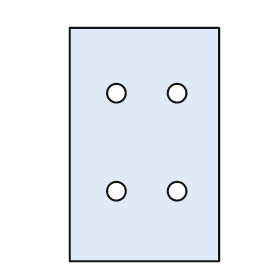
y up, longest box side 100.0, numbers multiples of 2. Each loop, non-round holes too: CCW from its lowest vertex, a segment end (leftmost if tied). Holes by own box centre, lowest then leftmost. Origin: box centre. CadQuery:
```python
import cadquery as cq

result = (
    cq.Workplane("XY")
    .moveTo(-32.0, -50.0)
    .lineTo(32.0, -50.0)
    .lineTo(32.0, 50.0)
    .lineTo(-32.0, 50.0)
    .close()
    .moveTo(-12.0, -20.0)
    .circle(4.0)
    .moveTo(14.0, -20.0)
    .circle(4.0)
    .moveTo(-12.0, 22.0)
    .circle(4.0)
    .moveTo(14.0, 22.0)
    .circle(4.0)
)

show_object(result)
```